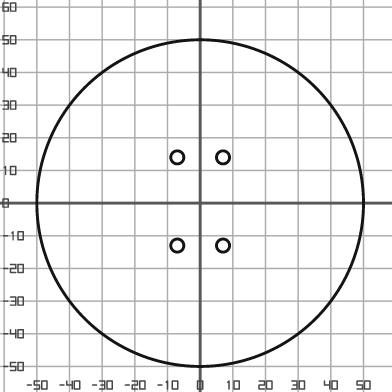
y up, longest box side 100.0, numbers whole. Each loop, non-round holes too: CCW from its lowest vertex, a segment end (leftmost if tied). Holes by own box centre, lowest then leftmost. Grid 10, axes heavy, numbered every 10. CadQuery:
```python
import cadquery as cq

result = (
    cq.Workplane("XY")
    .moveTo(0.0, 0.0)
    .circle(50.0)
    .moveTo(-7.0, -13.0)
    .circle(2.0)
    .moveTo(7.0, -13.0)
    .circle(2.0)
    .moveTo(-7.0, 14.0)
    .circle(2.0)
    .moveTo(7.0, 14.0)
    .circle(2.0)
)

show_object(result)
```